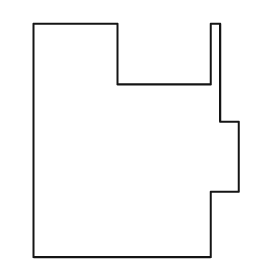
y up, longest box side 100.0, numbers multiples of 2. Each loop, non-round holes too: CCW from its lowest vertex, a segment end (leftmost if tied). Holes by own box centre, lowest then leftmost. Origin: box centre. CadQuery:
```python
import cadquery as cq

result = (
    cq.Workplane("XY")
    .moveTo(-44.0, -50.0)
    .lineTo(32.0, -50.0)
    .lineTo(32.0, -22.0)
    .lineTo(44.0, -22.0)
    .lineTo(44.0, 8.0)
    .lineTo(36.0, 8.0)
    .lineTo(36.0, 50.0)
    .lineTo(32.0, 50.0)
    .lineTo(32.0, 24.0)
    .lineTo(-8.0, 24.0)
    .lineTo(-8.0, 50.0)
    .lineTo(-44.0, 50.0)
    .close()
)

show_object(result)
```